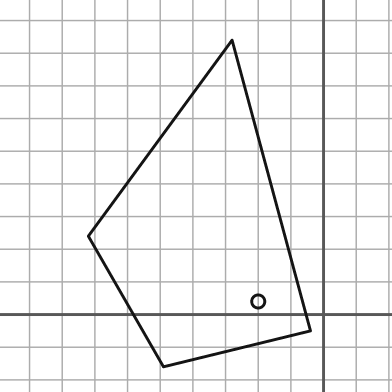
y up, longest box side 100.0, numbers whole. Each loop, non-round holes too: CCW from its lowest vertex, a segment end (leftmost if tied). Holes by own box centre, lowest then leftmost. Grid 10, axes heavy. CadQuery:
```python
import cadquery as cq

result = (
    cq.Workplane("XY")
    .moveTo(-49.0, -16.0)
    .lineTo(-4.0, -5.0)
    .lineTo(-28.0, 84.0)
    .lineTo(-72.0, 24.0)
    .close()
    .moveTo(-20.0, 4.0)
    .circle(2.0)
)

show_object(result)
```